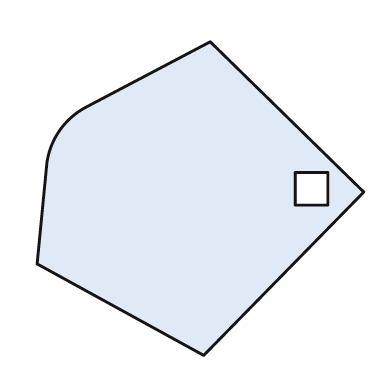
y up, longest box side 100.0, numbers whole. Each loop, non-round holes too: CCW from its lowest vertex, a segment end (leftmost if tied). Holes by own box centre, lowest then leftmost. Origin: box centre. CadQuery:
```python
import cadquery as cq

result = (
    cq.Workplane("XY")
    .moveTo(1.0, -48.0)
    .lineTo(50.0, 2.0)
    .lineTo(3.0, 48.0)
    .lineTo(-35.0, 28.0)
    .threePointArc((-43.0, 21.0), (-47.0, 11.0))
    .lineTo(-50.0, -20.0)
    .close()
    .moveTo(29.0, -2.0)
    .lineTo(39.0, -2.0)
    .lineTo(39.0, 8.0)
    .lineTo(29.0, 8.0)
    .close()
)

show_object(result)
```